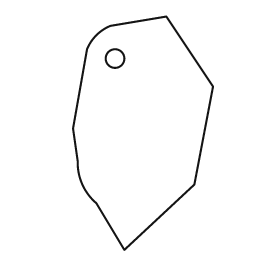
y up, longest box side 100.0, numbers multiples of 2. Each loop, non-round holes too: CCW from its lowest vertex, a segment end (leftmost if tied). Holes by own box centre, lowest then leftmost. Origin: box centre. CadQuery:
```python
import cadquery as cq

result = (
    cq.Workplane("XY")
    .moveTo(-8.0, -50.0)
    .lineTo(22.0, -22.0)
    .lineTo(30.0, 20.0)
    .lineTo(10.0, 50.0)
    .lineTo(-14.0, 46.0)
    .threePointArc((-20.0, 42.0), (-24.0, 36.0))
    .lineTo(-30.0, 2.0)
    .lineTo(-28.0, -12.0)
    .threePointArc((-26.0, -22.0), (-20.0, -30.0))
    .close()
    .moveTo(-12.0, 32.0)
    .circle(4.0)
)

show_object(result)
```